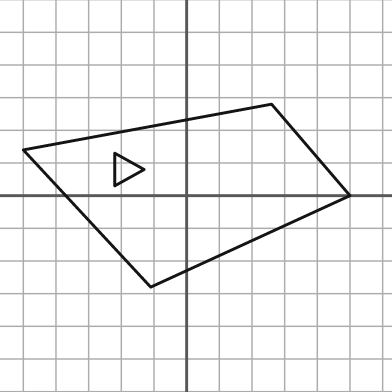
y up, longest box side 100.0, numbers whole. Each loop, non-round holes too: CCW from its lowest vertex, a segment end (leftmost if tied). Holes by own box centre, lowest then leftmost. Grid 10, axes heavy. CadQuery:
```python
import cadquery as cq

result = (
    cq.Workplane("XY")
    .moveTo(-11.0, -28.0)
    .lineTo(50.0, 0.0)
    .lineTo(26.0, 28.0)
    .lineTo(-50.0, 14.0)
    .close()
    .moveTo(-22.0, 3.0)
    .lineTo(-13.0, 8.0)
    .lineTo(-22.0, 13.0)
    .close()
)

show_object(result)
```